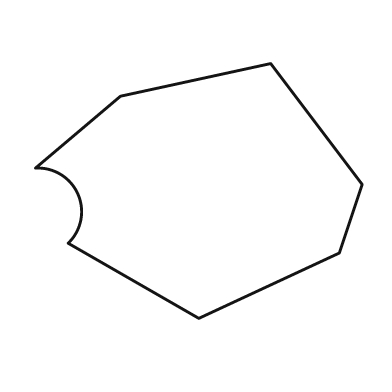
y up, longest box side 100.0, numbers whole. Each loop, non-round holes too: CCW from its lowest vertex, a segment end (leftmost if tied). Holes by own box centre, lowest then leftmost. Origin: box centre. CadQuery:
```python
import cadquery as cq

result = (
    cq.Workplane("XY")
    .moveTo(0.0, -39.0)
    .lineTo(43.0, -19.0)
    .lineTo(50.0, 2.0)
    .lineTo(22.0, 39.0)
    .lineTo(-24.0, 29.0)
    .lineTo(-50.0, 7.0)
    .threePointArc((-37.0, -1.0), (-40.0, -16.0))
    .close()
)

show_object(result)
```